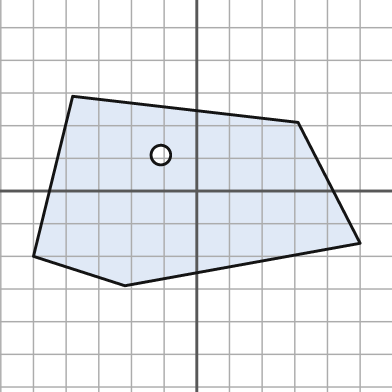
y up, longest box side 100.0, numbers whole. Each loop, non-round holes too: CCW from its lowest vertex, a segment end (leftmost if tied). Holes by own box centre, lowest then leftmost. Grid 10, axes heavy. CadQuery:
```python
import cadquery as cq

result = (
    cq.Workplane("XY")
    .moveTo(-22.0, -29.0)
    .lineTo(50.0, -16.0)
    .lineTo(31.0, 21.0)
    .lineTo(-38.0, 29.0)
    .lineTo(-50.0, -20.0)
    .close()
    .moveTo(-11.0, 11.0)
    .circle(3.0)
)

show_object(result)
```